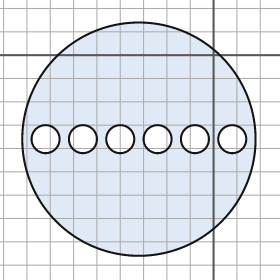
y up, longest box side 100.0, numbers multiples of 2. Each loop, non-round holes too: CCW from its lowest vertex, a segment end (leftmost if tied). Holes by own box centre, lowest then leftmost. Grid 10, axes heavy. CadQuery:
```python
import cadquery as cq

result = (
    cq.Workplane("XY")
    .moveTo(-32.0, -36.0)
    .circle(50.0)
    .moveTo(-72.0, -36.0)
    .circle(6.0)
    .moveTo(-56.0, -36.0)
    .circle(6.0)
    .moveTo(-40.0, -36.0)
    .circle(6.0)
    .moveTo(-24.0, -36.0)
    .circle(6.0)
    .moveTo(-8.0, -36.0)
    .circle(6.0)
    .moveTo(8.0, -36.0)
    .circle(6.0)
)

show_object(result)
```